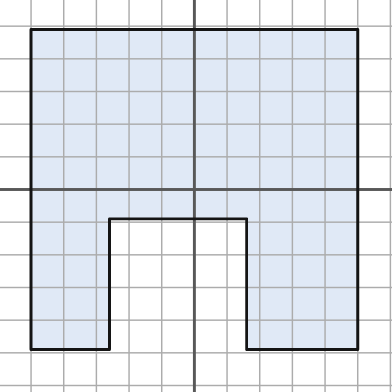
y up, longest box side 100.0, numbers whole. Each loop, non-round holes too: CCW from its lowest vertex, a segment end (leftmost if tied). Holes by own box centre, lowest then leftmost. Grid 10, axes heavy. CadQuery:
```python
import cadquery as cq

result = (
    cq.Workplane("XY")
    .moveTo(-50.0, -49.0)
    .lineTo(-26.0, -49.0)
    .lineTo(-26.0, -9.0)
    .lineTo(16.0, -9.0)
    .lineTo(16.0, -49.0)
    .lineTo(50.0, -49.0)
    .lineTo(50.0, 49.0)
    .lineTo(-50.0, 49.0)
    .close()
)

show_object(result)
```